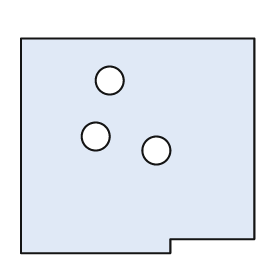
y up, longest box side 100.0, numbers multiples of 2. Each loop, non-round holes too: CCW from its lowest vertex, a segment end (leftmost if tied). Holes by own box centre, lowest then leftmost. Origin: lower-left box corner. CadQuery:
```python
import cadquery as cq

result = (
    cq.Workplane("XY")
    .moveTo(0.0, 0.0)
    .lineTo(64.0, 0.0)
    .lineTo(64.0, 6.0)
    .lineTo(100.0, 6.0)
    .lineTo(100.0, 92.0)
    .lineTo(0.0, 92.0)
    .close()
    .moveTo(58.0, 44.0)
    .circle(6.0)
    .moveTo(32.0, 50.0)
    .circle(6.0)
    .moveTo(38.0, 74.0)
    .circle(6.0)
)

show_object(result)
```